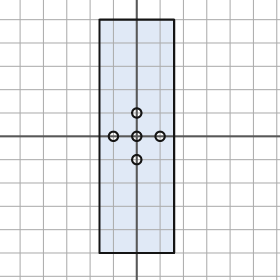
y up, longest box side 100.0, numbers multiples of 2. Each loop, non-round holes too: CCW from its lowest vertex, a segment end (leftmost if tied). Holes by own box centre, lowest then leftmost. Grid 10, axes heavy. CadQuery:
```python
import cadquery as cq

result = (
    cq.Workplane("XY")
    .moveTo(-16.0, -50.0)
    .lineTo(16.0, -50.0)
    .lineTo(16.0, 50.0)
    .lineTo(-16.0, 50.0)
    .close()
    .moveTo(0.0, -10.0)
    .circle(2.0)
    .moveTo(-10.0, 0.0)
    .circle(2.0)
    .moveTo(0.0, 0.0)
    .circle(2.0)
    .moveTo(10.0, 0.0)
    .circle(2.0)
    .moveTo(0.0, 10.0)
    .circle(2.0)
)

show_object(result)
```